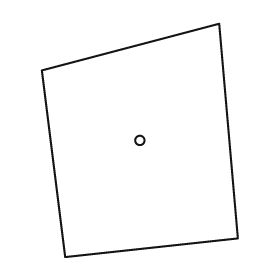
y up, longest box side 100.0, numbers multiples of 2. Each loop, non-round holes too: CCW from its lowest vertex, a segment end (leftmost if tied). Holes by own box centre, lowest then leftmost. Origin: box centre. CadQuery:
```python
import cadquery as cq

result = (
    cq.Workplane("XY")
    .moveTo(-32.0, -50.0)
    .lineTo(42.0, -42.0)
    .lineTo(34.0, 50.0)
    .lineTo(-42.0, 30.0)
    .close()
    .moveTo(0.0, 0.0)
    .circle(2.0)
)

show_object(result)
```